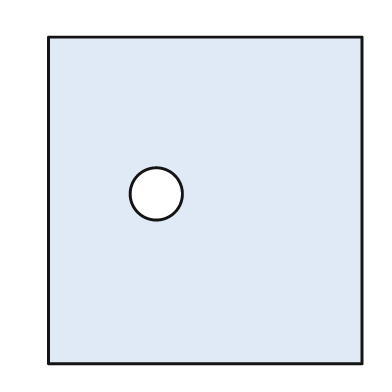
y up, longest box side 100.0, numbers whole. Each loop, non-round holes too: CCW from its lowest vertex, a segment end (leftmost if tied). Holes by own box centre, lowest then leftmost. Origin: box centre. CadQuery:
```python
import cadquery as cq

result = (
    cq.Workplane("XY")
    .moveTo(-48.0, -50.0)
    .lineTo(48.0, -50.0)
    .lineTo(48.0, 50.0)
    .lineTo(-48.0, 50.0)
    .close()
    .moveTo(-15.0, 2.0)
    .circle(8.0)
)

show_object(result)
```